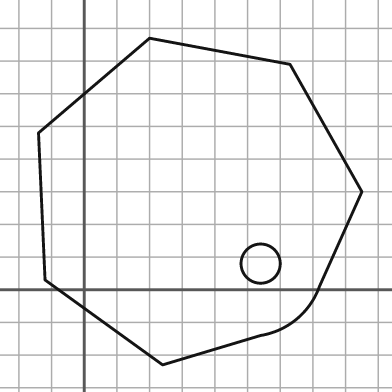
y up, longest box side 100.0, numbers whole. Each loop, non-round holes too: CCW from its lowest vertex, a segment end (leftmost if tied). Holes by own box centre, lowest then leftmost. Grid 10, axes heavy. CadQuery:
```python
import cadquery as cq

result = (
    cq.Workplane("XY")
    .moveTo(24.0, -23.0)
    .lineTo(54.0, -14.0)
    .threePointArc((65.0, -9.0), (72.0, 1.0))
    .lineTo(85.0, 30.0)
    .lineTo(63.0, 69.0)
    .lineTo(20.0, 77.0)
    .lineTo(-14.0, 48.0)
    .lineTo(-12.0, 3.0)
    .close()
    .moveTo(54.0, 8.0)
    .circle(6.0)
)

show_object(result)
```